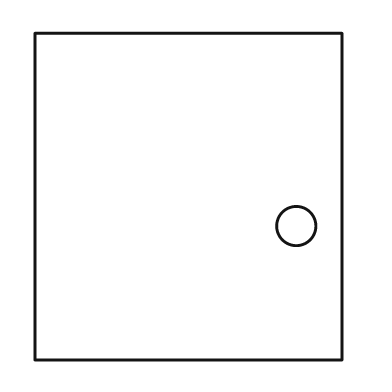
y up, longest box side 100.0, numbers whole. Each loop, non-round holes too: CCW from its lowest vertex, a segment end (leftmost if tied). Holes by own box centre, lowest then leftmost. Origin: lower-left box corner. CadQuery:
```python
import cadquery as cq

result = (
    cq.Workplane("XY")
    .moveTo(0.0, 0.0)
    .lineTo(94.0, 0.0)
    .lineTo(94.0, 100.0)
    .lineTo(0.0, 100.0)
    .close()
    .moveTo(80.0, 41.0)
    .circle(6.0)
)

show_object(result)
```